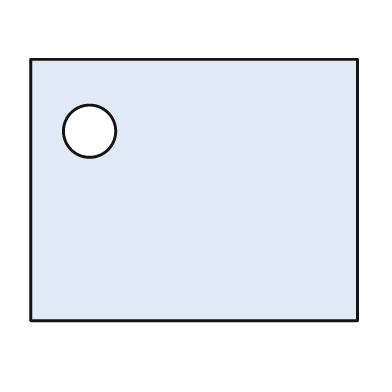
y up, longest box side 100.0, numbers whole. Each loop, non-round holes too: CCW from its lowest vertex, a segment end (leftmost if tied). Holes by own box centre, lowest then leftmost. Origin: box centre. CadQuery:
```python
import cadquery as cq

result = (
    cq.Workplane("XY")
    .moveTo(-50.0, -40.0)
    .lineTo(50.0, -40.0)
    .lineTo(50.0, 40.0)
    .lineTo(-50.0, 40.0)
    .close()
    .moveTo(-32.0, 18.0)
    .circle(8.0)
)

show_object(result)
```